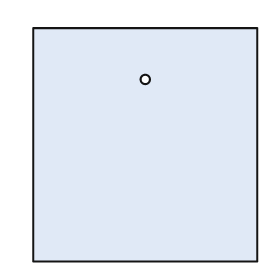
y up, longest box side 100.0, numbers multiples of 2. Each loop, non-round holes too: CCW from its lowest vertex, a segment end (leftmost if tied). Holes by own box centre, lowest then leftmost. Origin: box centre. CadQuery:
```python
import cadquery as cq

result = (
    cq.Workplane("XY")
    .moveTo(-48.0, -50.0)
    .lineTo(48.0, -50.0)
    .lineTo(48.0, 50.0)
    .lineTo(-48.0, 50.0)
    .close()
    .moveTo(0.0, 28.0)
    .circle(2.0)
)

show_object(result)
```